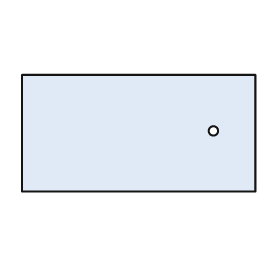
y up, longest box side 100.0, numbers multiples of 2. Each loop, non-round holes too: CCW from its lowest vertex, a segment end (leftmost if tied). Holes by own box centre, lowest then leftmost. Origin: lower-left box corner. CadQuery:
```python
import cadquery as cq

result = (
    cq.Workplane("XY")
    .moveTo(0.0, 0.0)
    .lineTo(100.0, 0.0)
    .lineTo(100.0, 50.0)
    .lineTo(0.0, 50.0)
    .close()
    .moveTo(82.0, 26.0)
    .circle(2.0)
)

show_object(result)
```